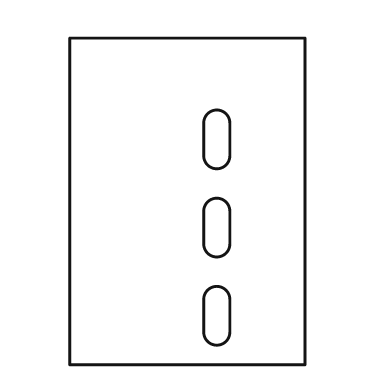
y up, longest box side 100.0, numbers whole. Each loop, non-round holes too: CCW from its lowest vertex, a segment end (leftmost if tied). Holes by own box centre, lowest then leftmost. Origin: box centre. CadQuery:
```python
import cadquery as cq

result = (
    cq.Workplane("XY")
    .moveTo(-36.0, -50.0)
    .lineTo(36.0, -50.0)
    .lineTo(36.0, 50.0)
    .lineTo(-36.0, 50.0)
    .close()
    .moveTo(5.0, -40.0)
    .threePointArc((9.0, -44.0), (13.0, -40.0))
    .lineTo(13.0, -30.0)
    .threePointArc((9.0, -26.0), (5.0, -30.0))
    .close()
    .moveTo(5.0, -13.0)
    .threePointArc((9.0, -17.0), (13.0, -13.0))
    .lineTo(13.0, -3.0)
    .threePointArc((9.0, 1.0), (5.0, -3.0))
    .close()
    .moveTo(5.0, 14.0)
    .threePointArc((9.0, 10.0), (13.0, 14.0))
    .lineTo(13.0, 24.0)
    .threePointArc((9.0, 28.0), (5.0, 24.0))
    .close()
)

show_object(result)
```